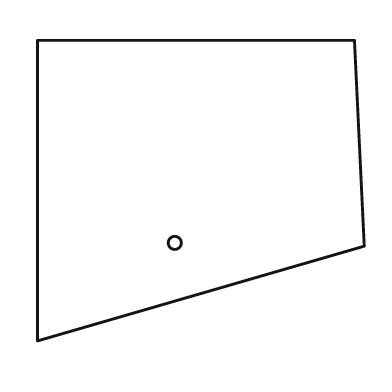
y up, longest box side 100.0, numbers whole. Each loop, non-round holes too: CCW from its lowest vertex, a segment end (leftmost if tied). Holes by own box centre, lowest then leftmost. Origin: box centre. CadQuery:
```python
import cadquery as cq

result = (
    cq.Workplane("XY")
    .moveTo(-50.0, -46.0)
    .lineTo(50.0, -17.0)
    .lineTo(47.0, 46.0)
    .lineTo(-50.0, 46.0)
    .close()
    .moveTo(-8.0, -16.0)
    .circle(2.0)
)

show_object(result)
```